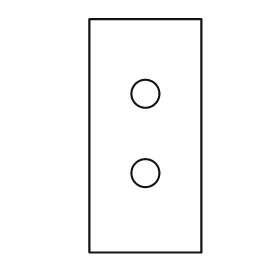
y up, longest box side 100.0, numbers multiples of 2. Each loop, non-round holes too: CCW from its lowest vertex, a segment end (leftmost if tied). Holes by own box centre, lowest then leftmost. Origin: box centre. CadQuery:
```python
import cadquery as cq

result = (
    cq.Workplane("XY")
    .moveTo(-24.0, -50.0)
    .lineTo(24.0, -50.0)
    .lineTo(24.0, 50.0)
    .lineTo(-24.0, 50.0)
    .close()
    .moveTo(0.0, -16.0)
    .circle(6.0)
    .moveTo(0.0, 18.0)
    .circle(6.0)
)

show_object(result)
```